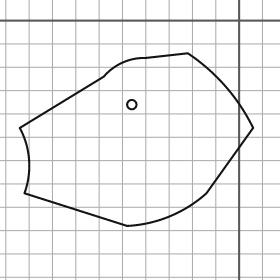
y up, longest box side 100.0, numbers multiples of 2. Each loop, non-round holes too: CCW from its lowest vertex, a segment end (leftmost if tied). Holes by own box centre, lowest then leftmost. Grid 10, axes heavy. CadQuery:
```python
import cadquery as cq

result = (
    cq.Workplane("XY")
    .moveTo(-48.0, -88.0)
    .threePointArc((-30.0, -84.0), (-14.0, -74.0))
    .lineTo(6.0, -46.0)
    .threePointArc((-6.0, -28.0), (-22.0, -14.0))
    .lineTo(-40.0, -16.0)
    .threePointArc((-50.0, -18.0), (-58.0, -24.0))
    .lineTo(-94.0, -46.0)
    .threePointArc((-90.0, -60.0), (-92.0, -74.0))
    .close()
    .moveTo(-46.0, -36.0)
    .circle(2.0)
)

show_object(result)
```